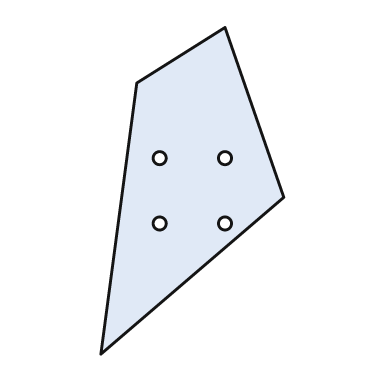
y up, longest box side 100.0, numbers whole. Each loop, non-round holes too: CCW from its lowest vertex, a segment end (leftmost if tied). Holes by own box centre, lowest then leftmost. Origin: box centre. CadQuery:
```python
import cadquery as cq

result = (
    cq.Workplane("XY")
    .moveTo(-28.0, -50.0)
    .lineTo(28.0, -2.0)
    .lineTo(10.0, 50.0)
    .lineTo(-17.0, 33.0)
    .close()
    .moveTo(-10.0, -10.0)
    .circle(2.0)
    .moveTo(10.0, -10.0)
    .circle(2.0)
    .moveTo(-10.0, 10.0)
    .circle(2.0)
    .moveTo(10.0, 10.0)
    .circle(2.0)
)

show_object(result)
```